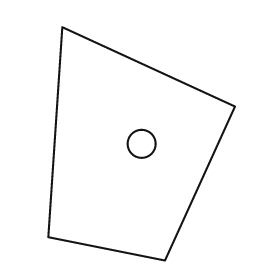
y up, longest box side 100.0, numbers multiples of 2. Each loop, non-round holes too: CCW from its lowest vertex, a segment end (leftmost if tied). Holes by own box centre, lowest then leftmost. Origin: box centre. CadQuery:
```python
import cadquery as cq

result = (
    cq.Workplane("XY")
    .moveTo(10.0, -50.0)
    .lineTo(40.0, 16.0)
    .lineTo(-34.0, 50.0)
    .lineTo(-40.0, -40.0)
    .close()
    .moveTo(0.0, 0.0)
    .circle(6.0)
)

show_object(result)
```